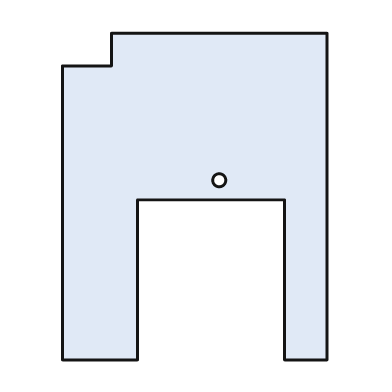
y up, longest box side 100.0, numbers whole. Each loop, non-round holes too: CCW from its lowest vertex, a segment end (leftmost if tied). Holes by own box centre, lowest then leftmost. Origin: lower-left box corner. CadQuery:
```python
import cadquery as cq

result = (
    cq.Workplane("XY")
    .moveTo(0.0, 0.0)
    .lineTo(23.0, 0.0)
    .lineTo(23.0, 49.0)
    .lineTo(68.0, 49.0)
    .lineTo(68.0, 0.0)
    .lineTo(81.0, 0.0)
    .lineTo(81.0, 100.0)
    .lineTo(15.0, 100.0)
    .lineTo(15.0, 90.0)
    .lineTo(0.0, 90.0)
    .close()
    .moveTo(48.0, 55.0)
    .circle(2.0)
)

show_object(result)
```